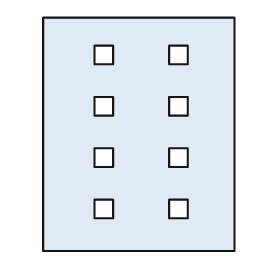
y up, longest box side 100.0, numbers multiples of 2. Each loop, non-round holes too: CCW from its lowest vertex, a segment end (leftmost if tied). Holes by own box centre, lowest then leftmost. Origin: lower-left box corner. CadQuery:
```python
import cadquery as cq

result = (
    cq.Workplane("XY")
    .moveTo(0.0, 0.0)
    .lineTo(82.0, 0.0)
    .lineTo(82.0, 100.0)
    .lineTo(0.0, 100.0)
    .close()
    .moveTo(22.0, 14.0)
    .lineTo(30.0, 14.0)
    .lineTo(30.0, 22.0)
    .lineTo(22.0, 22.0)
    .close()
    .moveTo(54.0, 14.0)
    .lineTo(62.0, 14.0)
    .lineTo(62.0, 22.0)
    .lineTo(54.0, 22.0)
    .close()
    .moveTo(22.0, 36.0)
    .lineTo(30.0, 36.0)
    .lineTo(30.0, 44.0)
    .lineTo(22.0, 44.0)
    .close()
    .moveTo(54.0, 36.0)
    .lineTo(62.0, 36.0)
    .lineTo(62.0, 44.0)
    .lineTo(54.0, 44.0)
    .close()
    .moveTo(22.0, 58.0)
    .lineTo(30.0, 58.0)
    .lineTo(30.0, 66.0)
    .lineTo(22.0, 66.0)
    .close()
    .moveTo(54.0, 58.0)
    .lineTo(62.0, 58.0)
    .lineTo(62.0, 66.0)
    .lineTo(54.0, 66.0)
    .close()
    .moveTo(22.0, 80.0)
    .lineTo(30.0, 80.0)
    .lineTo(30.0, 88.0)
    .lineTo(22.0, 88.0)
    .close()
    .moveTo(54.0, 80.0)
    .lineTo(62.0, 80.0)
    .lineTo(62.0, 88.0)
    .lineTo(54.0, 88.0)
    .close()
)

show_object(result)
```